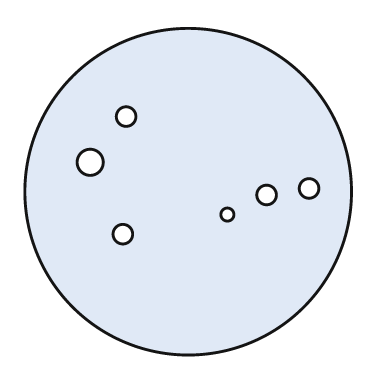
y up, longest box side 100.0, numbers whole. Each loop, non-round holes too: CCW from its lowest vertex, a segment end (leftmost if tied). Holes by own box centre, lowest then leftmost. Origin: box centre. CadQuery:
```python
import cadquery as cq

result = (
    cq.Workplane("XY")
    .moveTo(0.0, 0.0)
    .circle(50.0)
    .moveTo(-20.0, -13.0)
    .circle(3.0)
    .moveTo(12.0, -7.0)
    .circle(2.0)
    .moveTo(24.0, -1.0)
    .circle(3.0)
    .moveTo(37.0, 1.0)
    .circle(3.0)
    .moveTo(-30.0, 9.0)
    .circle(4.0)
    .moveTo(-19.0, 23.0)
    .circle(3.0)
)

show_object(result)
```